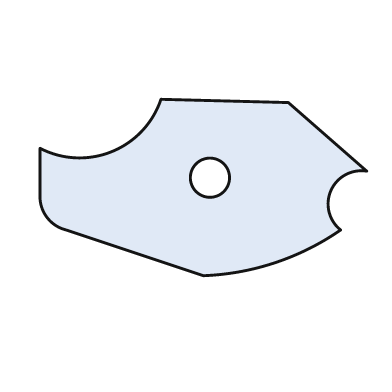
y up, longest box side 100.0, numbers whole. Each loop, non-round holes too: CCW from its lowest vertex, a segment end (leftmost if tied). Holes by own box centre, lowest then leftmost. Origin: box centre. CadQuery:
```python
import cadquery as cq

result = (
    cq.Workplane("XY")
    .moveTo(0.0, -27.0)
    .threePointArc((22.0, -23.0), (42.0, -13.0))
    .threePointArc((39.0, -1.0), (50.0, 5.0))
    .lineTo(26.0, 26.0)
    .lineTo(-13.0, 27.0)
    .threePointArc((-28.0, 11.0), (-50.0, 12.0))
    .lineTo(-50.0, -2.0)
    .threePointArc((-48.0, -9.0), (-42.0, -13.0))
    .close()
    .moveTo(2.0, 3.0)
    .circle(6.0)
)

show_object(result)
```